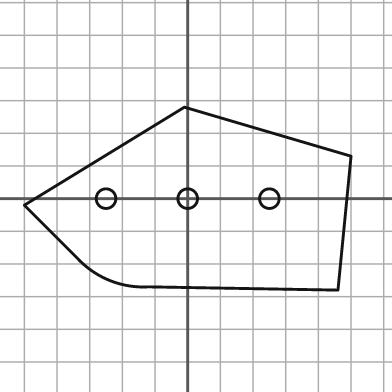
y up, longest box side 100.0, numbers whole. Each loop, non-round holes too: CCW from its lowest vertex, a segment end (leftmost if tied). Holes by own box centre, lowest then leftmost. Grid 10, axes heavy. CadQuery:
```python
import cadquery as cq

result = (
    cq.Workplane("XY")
    .moveTo(46.0, -28.0)
    .lineTo(50.0, 13.0)
    .lineTo(-1.0, 28.0)
    .lineTo(-50.0, -2.0)
    .lineTo(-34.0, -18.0)
    .threePointArc((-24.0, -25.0), (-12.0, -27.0))
    .close()
    .moveTo(-25.0, 0.0)
    .circle(3.0)
    .moveTo(0.0, 0.0)
    .circle(3.0)
    .moveTo(25.0, 0.0)
    .circle(3.0)
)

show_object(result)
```